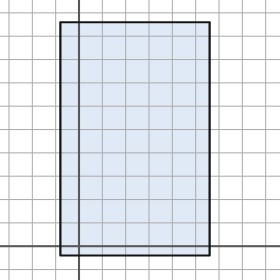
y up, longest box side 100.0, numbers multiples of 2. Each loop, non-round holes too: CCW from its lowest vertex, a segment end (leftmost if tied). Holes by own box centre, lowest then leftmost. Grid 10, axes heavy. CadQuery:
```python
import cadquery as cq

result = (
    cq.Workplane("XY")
    .moveTo(-8.0, -4.0)
    .lineTo(56.0, -4.0)
    .lineTo(56.0, 96.0)
    .lineTo(-8.0, 96.0)
    .close()
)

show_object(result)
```